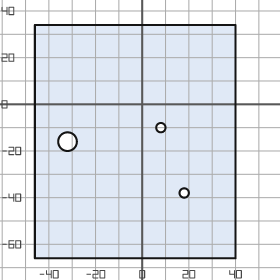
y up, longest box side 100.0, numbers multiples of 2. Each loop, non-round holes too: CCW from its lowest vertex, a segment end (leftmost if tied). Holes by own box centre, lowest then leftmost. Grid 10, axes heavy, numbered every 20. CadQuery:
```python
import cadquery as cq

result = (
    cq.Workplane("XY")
    .moveTo(-46.0, -66.0)
    .lineTo(40.0, -66.0)
    .lineTo(40.0, 34.0)
    .lineTo(-46.0, 34.0)
    .close()
    .moveTo(18.0, -38.0)
    .circle(2.0)
    .moveTo(-32.0, -16.0)
    .circle(4.0)
    .moveTo(8.0, -10.0)
    .circle(2.0)
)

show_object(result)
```